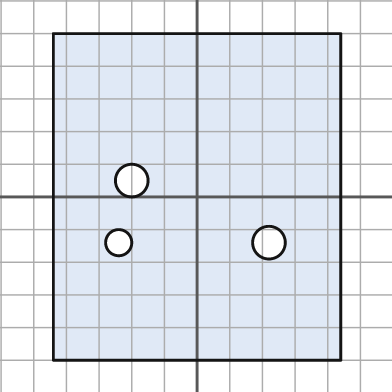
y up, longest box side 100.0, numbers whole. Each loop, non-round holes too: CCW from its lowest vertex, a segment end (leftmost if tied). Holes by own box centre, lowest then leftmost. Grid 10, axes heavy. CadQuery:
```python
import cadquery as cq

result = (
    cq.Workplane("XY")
    .moveTo(-44.0, -50.0)
    .lineTo(44.0, -50.0)
    .lineTo(44.0, 50.0)
    .lineTo(-44.0, 50.0)
    .close()
    .moveTo(-24.0, -14.0)
    .circle(4.0)
    .moveTo(22.0, -14.0)
    .circle(5.0)
    .moveTo(-20.0, 5.0)
    .circle(5.0)
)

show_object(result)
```